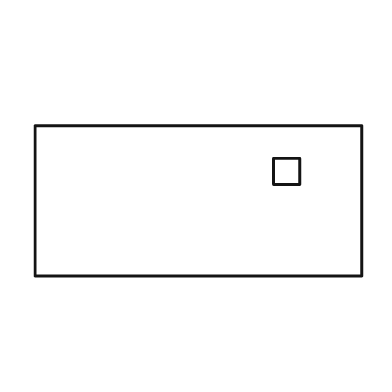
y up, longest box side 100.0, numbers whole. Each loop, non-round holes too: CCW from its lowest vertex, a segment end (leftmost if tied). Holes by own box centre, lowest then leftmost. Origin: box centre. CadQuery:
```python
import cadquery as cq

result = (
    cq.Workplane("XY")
    .moveTo(-50.0, -23.0)
    .lineTo(50.0, -23.0)
    .lineTo(50.0, 23.0)
    .lineTo(-50.0, 23.0)
    .close()
    .moveTo(23.0, 5.0)
    .lineTo(31.0, 5.0)
    .lineTo(31.0, 13.0)
    .lineTo(23.0, 13.0)
    .close()
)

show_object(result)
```